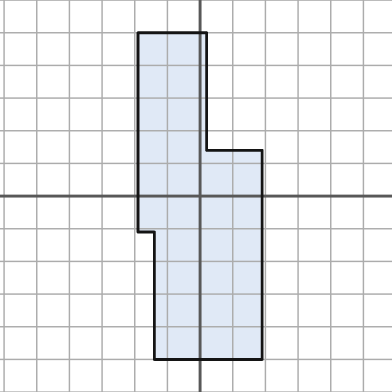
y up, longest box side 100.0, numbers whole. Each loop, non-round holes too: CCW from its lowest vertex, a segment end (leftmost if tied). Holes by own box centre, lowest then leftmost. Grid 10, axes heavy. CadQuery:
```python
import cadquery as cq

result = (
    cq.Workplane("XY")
    .moveTo(-14.0, -50.0)
    .lineTo(19.0, -50.0)
    .lineTo(19.0, 14.0)
    .lineTo(2.0, 14.0)
    .lineTo(2.0, 50.0)
    .lineTo(-19.0, 50.0)
    .lineTo(-19.0, -11.0)
    .lineTo(-14.0, -11.0)
    .close()
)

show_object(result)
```